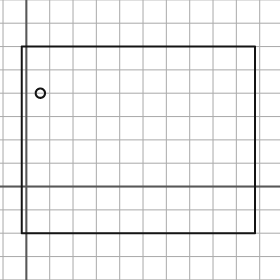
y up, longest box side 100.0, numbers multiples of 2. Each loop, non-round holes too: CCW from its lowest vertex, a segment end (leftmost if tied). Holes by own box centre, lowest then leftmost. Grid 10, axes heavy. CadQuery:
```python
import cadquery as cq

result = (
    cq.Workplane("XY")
    .moveTo(-2.0, -20.0)
    .lineTo(98.0, -20.0)
    .lineTo(98.0, 60.0)
    .lineTo(-2.0, 60.0)
    .close()
    .moveTo(6.0, 40.0)
    .circle(2.0)
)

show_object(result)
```